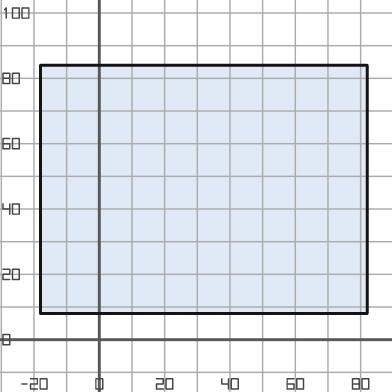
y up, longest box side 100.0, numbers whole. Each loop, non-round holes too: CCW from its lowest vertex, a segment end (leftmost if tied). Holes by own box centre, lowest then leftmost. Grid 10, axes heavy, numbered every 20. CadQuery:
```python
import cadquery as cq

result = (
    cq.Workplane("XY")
    .moveTo(-18.0, 8.0)
    .lineTo(82.0, 8.0)
    .lineTo(82.0, 84.0)
    .lineTo(-18.0, 84.0)
    .close()
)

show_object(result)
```